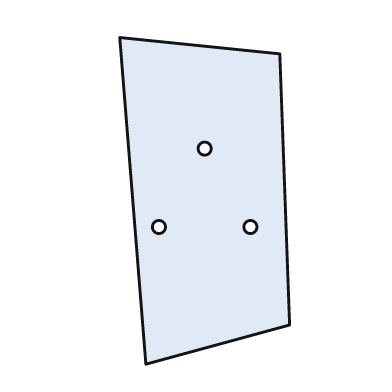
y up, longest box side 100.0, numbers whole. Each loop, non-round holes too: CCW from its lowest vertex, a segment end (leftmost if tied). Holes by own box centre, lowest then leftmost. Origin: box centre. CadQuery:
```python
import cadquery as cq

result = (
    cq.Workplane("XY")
    .moveTo(-18.0, -50.0)
    .lineTo(26.0, -38.0)
    .lineTo(23.0, 45.0)
    .lineTo(-26.0, 50.0)
    .close()
    .moveTo(-14.0, -8.0)
    .circle(2.0)
    .moveTo(14.0, -8.0)
    .circle(2.0)
    .moveTo(0.0, 16.0)
    .circle(2.0)
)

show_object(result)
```